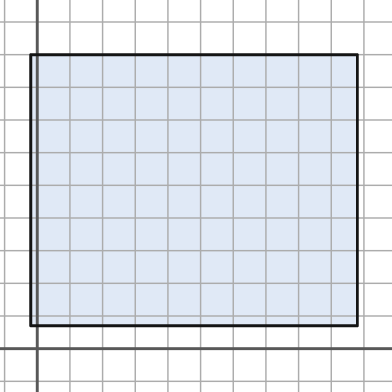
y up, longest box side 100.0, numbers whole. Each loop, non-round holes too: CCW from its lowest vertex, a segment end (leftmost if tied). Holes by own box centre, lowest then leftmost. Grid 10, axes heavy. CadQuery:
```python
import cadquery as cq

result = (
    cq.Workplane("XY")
    .moveTo(-2.0, 7.0)
    .lineTo(98.0, 7.0)
    .lineTo(98.0, 90.0)
    .lineTo(-2.0, 90.0)
    .close()
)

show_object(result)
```